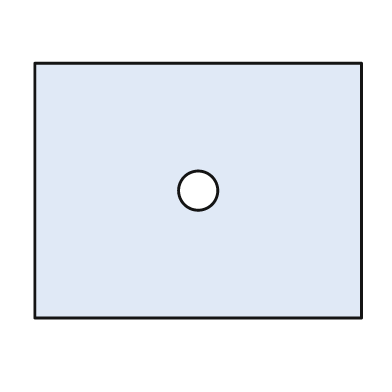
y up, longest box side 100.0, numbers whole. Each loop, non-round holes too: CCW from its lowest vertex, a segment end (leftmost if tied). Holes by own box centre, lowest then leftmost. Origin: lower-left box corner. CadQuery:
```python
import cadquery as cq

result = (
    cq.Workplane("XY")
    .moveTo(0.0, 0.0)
    .lineTo(100.0, 0.0)
    .lineTo(100.0, 78.0)
    .lineTo(0.0, 78.0)
    .close()
    .moveTo(50.0, 39.0)
    .circle(6.0)
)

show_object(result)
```